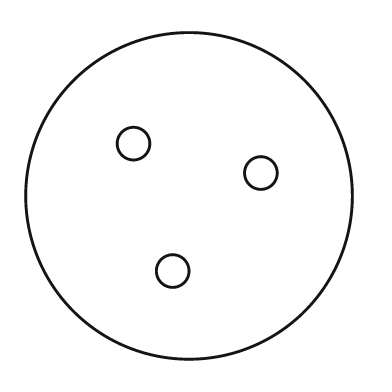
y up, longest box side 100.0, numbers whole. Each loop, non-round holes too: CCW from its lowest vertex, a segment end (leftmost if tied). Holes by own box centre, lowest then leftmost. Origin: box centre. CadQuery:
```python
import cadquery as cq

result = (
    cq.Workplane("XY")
    .moveTo(0.0, 0.0)
    .circle(50.0)
    .moveTo(-5.0, -23.0)
    .circle(5.0)
    .moveTo(22.0, 7.0)
    .circle(5.0)
    .moveTo(-17.0, 16.0)
    .circle(5.0)
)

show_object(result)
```